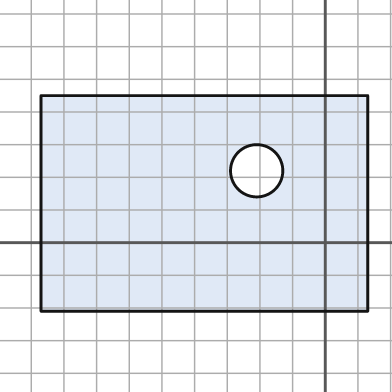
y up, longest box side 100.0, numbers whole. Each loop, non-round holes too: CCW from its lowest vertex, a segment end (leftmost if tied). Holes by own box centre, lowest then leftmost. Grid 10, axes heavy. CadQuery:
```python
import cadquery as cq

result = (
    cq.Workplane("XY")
    .moveTo(-87.0, -21.0)
    .lineTo(13.0, -21.0)
    .lineTo(13.0, 45.0)
    .lineTo(-87.0, 45.0)
    .close()
    .moveTo(-21.0, 22.0)
    .circle(8.0)
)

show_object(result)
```